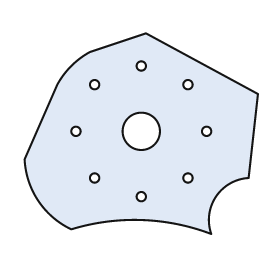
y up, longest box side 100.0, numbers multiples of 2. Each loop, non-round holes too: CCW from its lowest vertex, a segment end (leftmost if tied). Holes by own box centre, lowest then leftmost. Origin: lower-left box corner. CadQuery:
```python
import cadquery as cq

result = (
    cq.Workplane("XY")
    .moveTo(80.0, 0.0)
    .threePointArc((82.0, 16.0), (96.0, 24.0))
    .lineTo(100.0, 60.0)
    .lineTo(52.0, 86.0)
    .lineTo(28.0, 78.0)
    .threePointArc((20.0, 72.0), (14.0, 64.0))
    .lineTo(0.0, 32.0)
    .threePointArc((6.0, 14.0), (20.0, 2.0))
    .threePointArc((50.0, 6.0), (80.0, 0.0))
    .close()
    .moveTo(50.0, 16.0)
    .circle(2.0)
    .moveTo(30.0, 24.0)
    .circle(2.0)
    .moveTo(70.0, 24.0)
    .circle(2.0)
    .moveTo(22.0, 44.0)
    .circle(2.0)
    .moveTo(50.0, 44.0)
    .circle(8.0)
    .moveTo(78.0, 44.0)
    .circle(2.0)
    .moveTo(30.0, 64.0)
    .circle(2.0)
    .moveTo(70.0, 64.0)
    .circle(2.0)
    .moveTo(50.0, 72.0)
    .circle(2.0)
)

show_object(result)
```